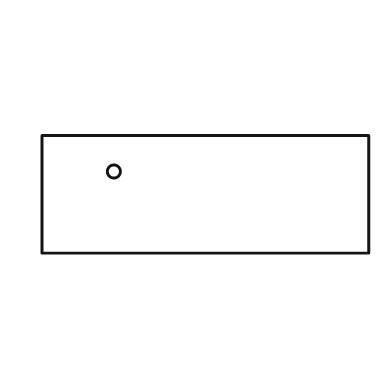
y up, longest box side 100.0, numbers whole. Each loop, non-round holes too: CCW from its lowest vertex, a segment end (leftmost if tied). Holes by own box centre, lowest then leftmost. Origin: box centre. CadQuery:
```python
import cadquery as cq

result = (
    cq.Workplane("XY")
    .moveTo(-50.0, -18.0)
    .lineTo(50.0, -18.0)
    .lineTo(50.0, 18.0)
    .lineTo(-50.0, 18.0)
    .close()
    .moveTo(-28.0, 7.0)
    .circle(2.0)
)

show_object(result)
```